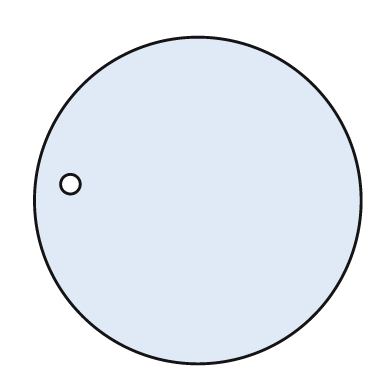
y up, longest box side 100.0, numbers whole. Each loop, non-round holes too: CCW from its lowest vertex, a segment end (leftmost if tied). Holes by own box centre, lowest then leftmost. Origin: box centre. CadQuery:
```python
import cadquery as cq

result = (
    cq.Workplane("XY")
    .moveTo(0.0, 0.0)
    .circle(50.0)
    .moveTo(-39.0, 5.0)
    .circle(3.0)
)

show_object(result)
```